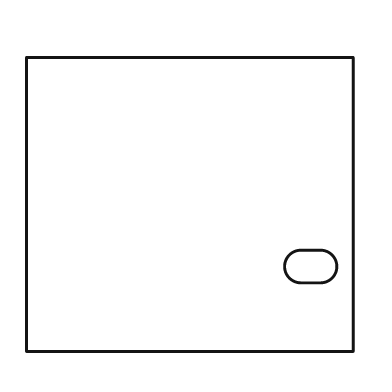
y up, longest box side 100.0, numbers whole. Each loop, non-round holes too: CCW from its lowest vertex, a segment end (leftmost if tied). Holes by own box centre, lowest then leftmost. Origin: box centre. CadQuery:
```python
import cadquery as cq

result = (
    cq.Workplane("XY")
    .moveTo(-50.0, -45.0)
    .lineTo(50.0, -45.0)
    .lineTo(50.0, 45.0)
    .lineTo(-50.0, 45.0)
    .close()
    .moveTo(34.0, -24.0)
    .lineTo(40.0, -24.0)
    .threePointArc((45.0, -19.0), (40.0, -14.0))
    .lineTo(34.0, -14.0)
    .threePointArc((29.0, -19.0), (34.0, -24.0))
    .close()
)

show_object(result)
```